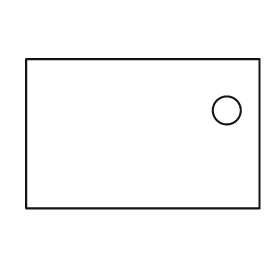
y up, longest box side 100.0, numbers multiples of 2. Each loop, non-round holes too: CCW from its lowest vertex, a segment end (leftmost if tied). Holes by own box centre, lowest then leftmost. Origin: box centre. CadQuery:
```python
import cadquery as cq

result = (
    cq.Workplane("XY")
    .moveTo(-50.0, -32.0)
    .lineTo(50.0, -32.0)
    .lineTo(50.0, 32.0)
    .lineTo(-50.0, 32.0)
    .close()
    .moveTo(36.0, 10.0)
    .circle(6.0)
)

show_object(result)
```